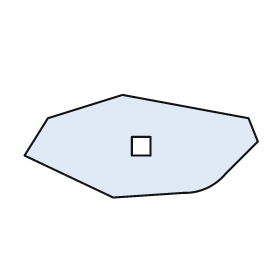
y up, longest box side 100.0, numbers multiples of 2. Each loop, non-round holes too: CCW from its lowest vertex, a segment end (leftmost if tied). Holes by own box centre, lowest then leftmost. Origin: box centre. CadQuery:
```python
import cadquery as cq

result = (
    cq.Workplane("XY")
    .moveTo(-12.0, -22.0)
    .lineTo(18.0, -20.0)
    .threePointArc((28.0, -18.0), (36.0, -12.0))
    .lineTo(50.0, 2.0)
    .lineTo(46.0, 12.0)
    .lineTo(-8.0, 22.0)
    .lineTo(-40.0, 12.0)
    .lineTo(-50.0, -4.0)
    .close()
    .moveTo(-4.0, -4.0)
    .lineTo(4.0, -4.0)
    .lineTo(4.0, 4.0)
    .lineTo(-4.0, 4.0)
    .close()
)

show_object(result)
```